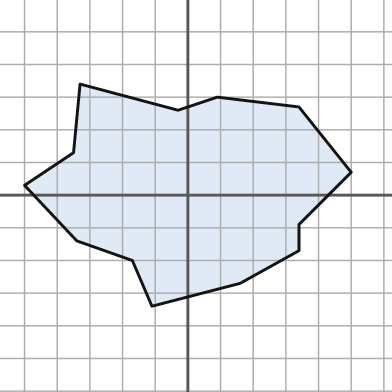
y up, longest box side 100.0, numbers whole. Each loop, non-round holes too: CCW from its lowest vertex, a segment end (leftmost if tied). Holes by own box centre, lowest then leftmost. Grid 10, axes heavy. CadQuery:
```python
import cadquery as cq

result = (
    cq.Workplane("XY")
    .moveTo(-11.0, -34.0)
    .lineTo(16.0, -27.0)
    .lineTo(34.0, -17.0)
    .lineTo(34.0, -9.0)
    .lineTo(50.0, 7.0)
    .lineTo(34.0, 27.0)
    .lineTo(9.0, 30.0)
    .lineTo(-3.0, 26.0)
    .lineTo(-33.0, 34.0)
    .lineTo(-35.0, 13.0)
    .lineTo(-50.0, 3.0)
    .lineTo(-34.0, -14.0)
    .lineTo(-17.0, -20.0)
    .close()
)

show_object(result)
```